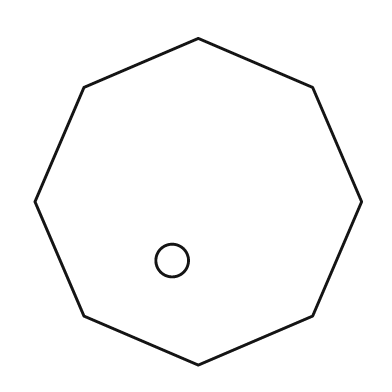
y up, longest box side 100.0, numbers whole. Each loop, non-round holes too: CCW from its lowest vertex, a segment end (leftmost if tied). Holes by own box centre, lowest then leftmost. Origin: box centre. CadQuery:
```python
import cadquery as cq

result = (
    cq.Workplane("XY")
    .moveTo(0.0, -50.0)
    .lineTo(35.0, -35.0)
    .lineTo(50.0, 0.0)
    .lineTo(35.0, 35.0)
    .lineTo(0.0, 50.0)
    .lineTo(-35.0, 35.0)
    .lineTo(-50.0, 0.0)
    .lineTo(-35.0, -35.0)
    .close()
    .moveTo(-8.0, -18.0)
    .circle(5.0)
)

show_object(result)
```